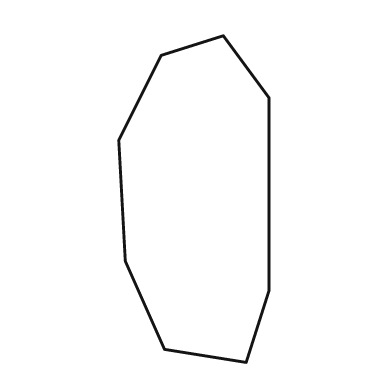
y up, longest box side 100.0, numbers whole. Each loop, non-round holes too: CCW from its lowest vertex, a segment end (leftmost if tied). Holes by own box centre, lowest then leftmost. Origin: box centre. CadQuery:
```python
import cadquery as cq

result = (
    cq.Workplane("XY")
    .moveTo(16.0, -50.0)
    .lineTo(23.0, -28.0)
    .lineTo(23.0, 31.0)
    .lineTo(9.0, 50.0)
    .lineTo(-10.0, 44.0)
    .lineTo(-23.0, 18.0)
    .lineTo(-21.0, -19.0)
    .lineTo(-9.0, -46.0)
    .close()
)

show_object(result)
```